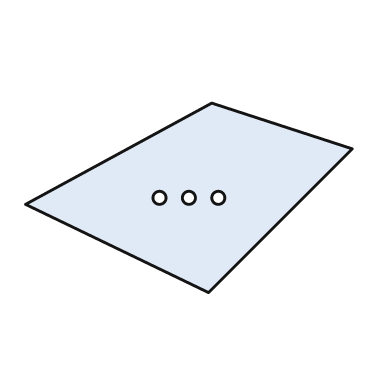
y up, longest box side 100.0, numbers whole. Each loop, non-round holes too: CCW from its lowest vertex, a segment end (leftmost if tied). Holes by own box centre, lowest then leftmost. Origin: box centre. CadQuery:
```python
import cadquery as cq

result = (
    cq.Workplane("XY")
    .moveTo(6.0, -29.0)
    .lineTo(50.0, 15.0)
    .lineTo(7.0, 29.0)
    .lineTo(-50.0, -2.0)
    .close()
    .moveTo(-9.0, 0.0)
    .circle(2.0)
    .moveTo(0.0, 0.0)
    .circle(2.0)
    .moveTo(9.0, 0.0)
    .circle(2.0)
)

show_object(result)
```